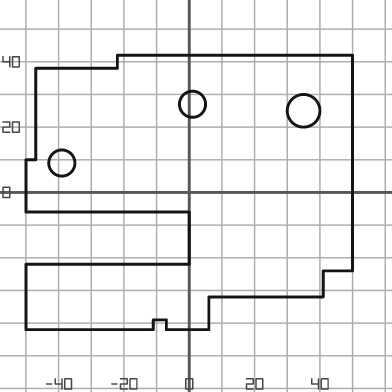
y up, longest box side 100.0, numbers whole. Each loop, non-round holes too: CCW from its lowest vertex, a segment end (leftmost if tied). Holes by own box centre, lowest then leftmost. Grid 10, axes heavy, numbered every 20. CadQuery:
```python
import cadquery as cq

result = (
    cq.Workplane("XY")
    .moveTo(-50.0, -42.0)
    .lineTo(-11.0, -42.0)
    .lineTo(-11.0, -39.0)
    .lineTo(-7.0, -39.0)
    .lineTo(-7.0, -42.0)
    .lineTo(6.0, -42.0)
    .lineTo(6.0, -32.0)
    .lineTo(41.0, -32.0)
    .lineTo(41.0, -24.0)
    .lineTo(50.0, -24.0)
    .lineTo(50.0, 42.0)
    .lineTo(-22.0, 42.0)
    .lineTo(-22.0, 38.0)
    .lineTo(-47.0, 38.0)
    .lineTo(-47.0, 10.0)
    .lineTo(-50.0, 10.0)
    .lineTo(-50.0, -6.0)
    .lineTo(0.0, -6.0)
    .lineTo(0.0, -22.0)
    .lineTo(-50.0, -22.0)
    .close()
    .moveTo(-39.0, 9.0)
    .circle(4.0)
    .moveTo(35.0, 25.0)
    .circle(5.0)
    .moveTo(1.0, 27.0)
    .circle(4.0)
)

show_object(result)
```